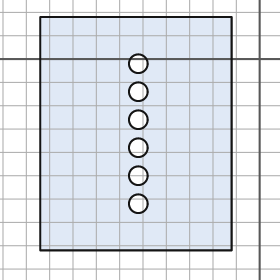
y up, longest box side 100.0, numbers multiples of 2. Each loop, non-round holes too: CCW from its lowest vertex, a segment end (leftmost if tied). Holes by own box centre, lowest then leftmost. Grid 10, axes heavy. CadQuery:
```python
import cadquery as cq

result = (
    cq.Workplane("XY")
    .moveTo(-94.0, -82.0)
    .lineTo(-12.0, -82.0)
    .lineTo(-12.0, 18.0)
    .lineTo(-94.0, 18.0)
    .close()
    .moveTo(-52.0, -62.0)
    .circle(4.0)
    .moveTo(-52.0, -50.0)
    .circle(4.0)
    .moveTo(-52.0, -38.0)
    .circle(4.0)
    .moveTo(-52.0, -26.0)
    .circle(4.0)
    .moveTo(-52.0, -14.0)
    .circle(4.0)
    .moveTo(-52.0, -2.0)
    .circle(4.0)
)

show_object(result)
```